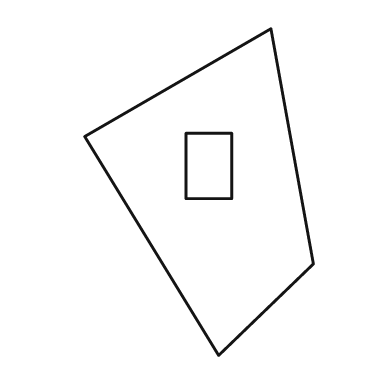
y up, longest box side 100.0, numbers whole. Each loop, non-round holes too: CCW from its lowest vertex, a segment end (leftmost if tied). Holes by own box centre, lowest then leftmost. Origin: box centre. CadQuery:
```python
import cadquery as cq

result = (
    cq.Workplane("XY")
    .moveTo(6.0, -50.0)
    .lineTo(35.0, -22.0)
    .lineTo(22.0, 50.0)
    .lineTo(-35.0, 17.0)
    .close()
    .moveTo(-4.0, -2.0)
    .lineTo(10.0, -2.0)
    .lineTo(10.0, 18.0)
    .lineTo(-4.0, 18.0)
    .close()
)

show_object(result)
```